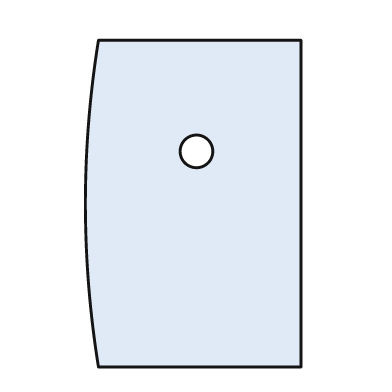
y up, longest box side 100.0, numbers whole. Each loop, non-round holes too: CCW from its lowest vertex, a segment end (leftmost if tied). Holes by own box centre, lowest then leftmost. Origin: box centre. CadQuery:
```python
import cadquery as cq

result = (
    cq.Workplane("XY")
    .moveTo(-29.0, -50.0)
    .lineTo(33.0, -50.0)
    .lineTo(33.0, 50.0)
    .lineTo(-29.0, 50.0)
    .threePointArc((-33.0, 0.0), (-29.0, -50.0))
    .close()
    .moveTo(1.0, 16.0)
    .circle(5.0)
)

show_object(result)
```